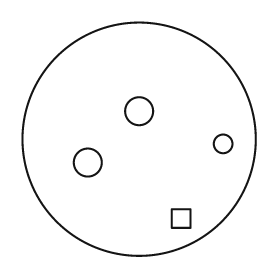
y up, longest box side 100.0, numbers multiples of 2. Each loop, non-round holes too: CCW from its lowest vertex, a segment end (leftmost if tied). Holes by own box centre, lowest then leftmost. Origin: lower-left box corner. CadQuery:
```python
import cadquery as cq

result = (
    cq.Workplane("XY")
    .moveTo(50.0, 50.0)
    .circle(50.0)
    .moveTo(64.0, 12.0)
    .lineTo(72.0, 12.0)
    .lineTo(72.0, 20.0)
    .lineTo(64.0, 20.0)
    .close()
    .moveTo(28.0, 40.0)
    .circle(6.0)
    .moveTo(86.0, 48.0)
    .circle(4.0)
    .moveTo(50.0, 62.0)
    .circle(6.0)
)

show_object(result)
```